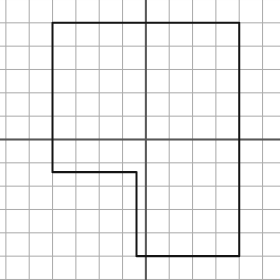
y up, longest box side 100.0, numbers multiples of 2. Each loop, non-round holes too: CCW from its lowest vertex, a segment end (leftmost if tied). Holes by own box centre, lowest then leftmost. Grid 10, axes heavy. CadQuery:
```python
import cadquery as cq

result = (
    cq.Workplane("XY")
    .moveTo(-4.0, -50.0)
    .lineTo(40.0, -50.0)
    .lineTo(40.0, 50.0)
    .lineTo(-40.0, 50.0)
    .lineTo(-40.0, -14.0)
    .lineTo(-4.0, -14.0)
    .close()
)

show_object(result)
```